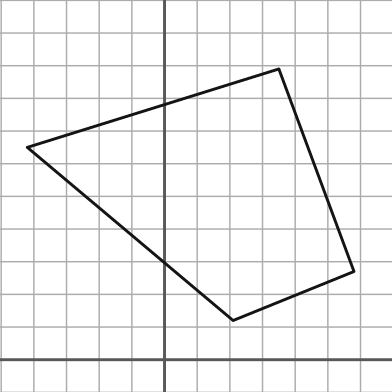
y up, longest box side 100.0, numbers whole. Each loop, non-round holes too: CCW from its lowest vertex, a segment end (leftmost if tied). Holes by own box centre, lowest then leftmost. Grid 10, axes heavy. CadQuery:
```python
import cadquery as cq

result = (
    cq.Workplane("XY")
    .moveTo(21.0, 12.0)
    .lineTo(58.0, 27.0)
    .lineTo(35.0, 89.0)
    .lineTo(-42.0, 65.0)
    .close()
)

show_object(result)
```